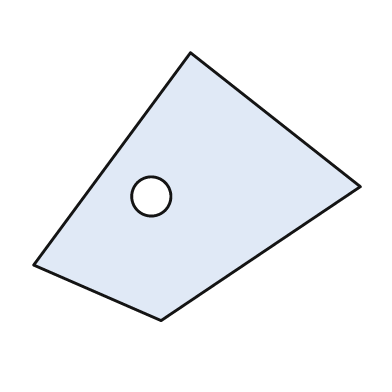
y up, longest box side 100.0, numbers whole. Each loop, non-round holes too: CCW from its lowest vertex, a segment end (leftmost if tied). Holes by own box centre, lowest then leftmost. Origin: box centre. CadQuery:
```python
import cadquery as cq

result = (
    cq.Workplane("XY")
    .moveTo(-11.0, -41.0)
    .lineTo(50.0, 0.0)
    .lineTo(-2.0, 41.0)
    .lineTo(-50.0, -24.0)
    .close()
    .moveTo(-14.0, -3.0)
    .circle(6.0)
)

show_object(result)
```